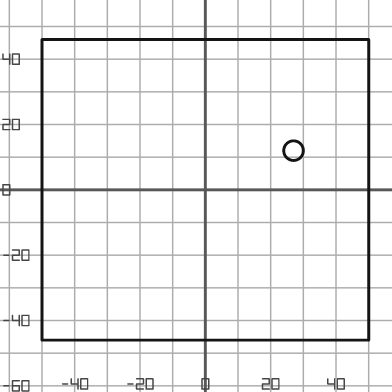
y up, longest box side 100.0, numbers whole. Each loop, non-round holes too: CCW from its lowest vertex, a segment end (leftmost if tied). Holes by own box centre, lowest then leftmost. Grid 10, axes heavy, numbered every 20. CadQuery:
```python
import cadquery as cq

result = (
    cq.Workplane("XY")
    .moveTo(-50.0, -46.0)
    .lineTo(50.0, -46.0)
    .lineTo(50.0, 46.0)
    .lineTo(-50.0, 46.0)
    .close()
    .moveTo(27.0, 12.0)
    .circle(3.0)
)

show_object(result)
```